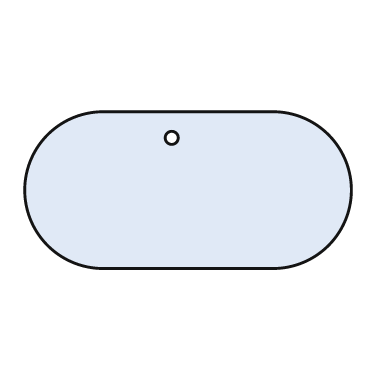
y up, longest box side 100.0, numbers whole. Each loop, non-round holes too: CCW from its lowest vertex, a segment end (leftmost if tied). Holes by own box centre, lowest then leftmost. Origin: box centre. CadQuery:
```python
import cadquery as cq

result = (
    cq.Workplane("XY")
    .moveTo(-26.0, -24.0)
    .lineTo(26.0, -24.0)
    .threePointArc((50.0, 0.0), (26.0, 24.0))
    .lineTo(-26.0, 24.0)
    .threePointArc((-50.0, 0.0), (-26.0, -24.0))
    .close()
    .moveTo(-5.0, 16.0)
    .circle(2.0)
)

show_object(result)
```